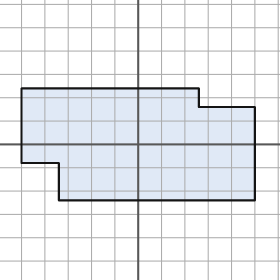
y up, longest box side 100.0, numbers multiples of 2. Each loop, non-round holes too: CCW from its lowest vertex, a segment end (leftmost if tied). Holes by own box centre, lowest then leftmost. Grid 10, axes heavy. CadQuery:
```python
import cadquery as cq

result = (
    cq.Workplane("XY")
    .moveTo(-34.0, -24.0)
    .lineTo(50.0, -24.0)
    .lineTo(50.0, 16.0)
    .lineTo(26.0, 16.0)
    .lineTo(26.0, 24.0)
    .lineTo(-50.0, 24.0)
    .lineTo(-50.0, -8.0)
    .lineTo(-34.0, -8.0)
    .close()
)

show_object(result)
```